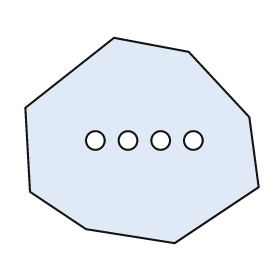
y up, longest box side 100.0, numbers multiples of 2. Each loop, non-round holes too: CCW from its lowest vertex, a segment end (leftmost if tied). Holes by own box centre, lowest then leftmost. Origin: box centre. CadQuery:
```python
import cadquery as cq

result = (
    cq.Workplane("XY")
    .moveTo(14.0, -44.0)
    .lineTo(50.0, -20.0)
    .lineTo(46.0, 10.0)
    .lineTo(20.0, 38.0)
    .lineTo(-12.0, 44.0)
    .lineTo(-50.0, 14.0)
    .lineTo(-48.0, -22.0)
    .lineTo(-24.0, -38.0)
    .close()
    .moveTo(-20.0, 0.0)
    .circle(4.0)
    .moveTo(-6.0, 0.0)
    .circle(4.0)
    .moveTo(8.0, 0.0)
    .circle(4.0)
    .moveTo(22.0, 0.0)
    .circle(4.0)
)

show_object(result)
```